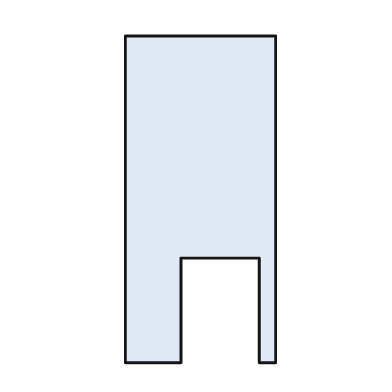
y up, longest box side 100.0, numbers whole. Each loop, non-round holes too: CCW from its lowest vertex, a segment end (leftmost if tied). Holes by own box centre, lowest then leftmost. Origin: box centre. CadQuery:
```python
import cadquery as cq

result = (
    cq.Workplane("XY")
    .moveTo(-23.0, -50.0)
    .lineTo(-6.0, -50.0)
    .lineTo(-6.0, -18.0)
    .lineTo(18.0, -18.0)
    .lineTo(18.0, -50.0)
    .lineTo(23.0, -50.0)
    .lineTo(23.0, 50.0)
    .lineTo(-23.0, 50.0)
    .close()
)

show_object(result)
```